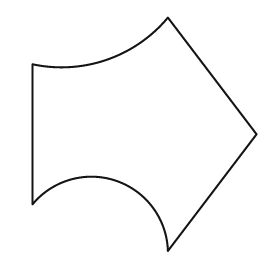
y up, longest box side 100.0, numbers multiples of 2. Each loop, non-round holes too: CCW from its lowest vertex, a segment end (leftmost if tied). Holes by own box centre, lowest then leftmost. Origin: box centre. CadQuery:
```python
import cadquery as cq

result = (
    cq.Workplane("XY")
    .moveTo(10.0, -50.0)
    .lineTo(48.0, 0.0)
    .lineTo(10.0, 50.0)
    .threePointArc((-16.0, 32.0), (-48.0, 30.0))
    .lineTo(-48.0, -30.0)
    .threePointArc((-12.0, -20.0), (10.0, -50.0))
    .close()
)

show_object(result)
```